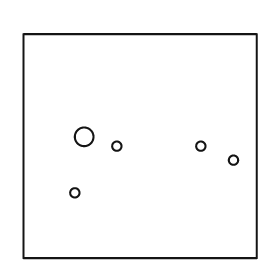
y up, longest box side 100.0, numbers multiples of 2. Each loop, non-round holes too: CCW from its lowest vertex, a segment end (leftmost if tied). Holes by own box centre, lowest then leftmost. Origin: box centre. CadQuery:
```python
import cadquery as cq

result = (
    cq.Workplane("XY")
    .moveTo(-50.0, -48.0)
    .lineTo(50.0, -48.0)
    .lineTo(50.0, 48.0)
    .lineTo(-50.0, 48.0)
    .close()
    .moveTo(-28.0, -20.0)
    .circle(2.0)
    .moveTo(40.0, -6.0)
    .circle(2.0)
    .moveTo(-10.0, 0.0)
    .circle(2.0)
    .moveTo(26.0, 0.0)
    .circle(2.0)
    .moveTo(-24.0, 4.0)
    .circle(4.0)
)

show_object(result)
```